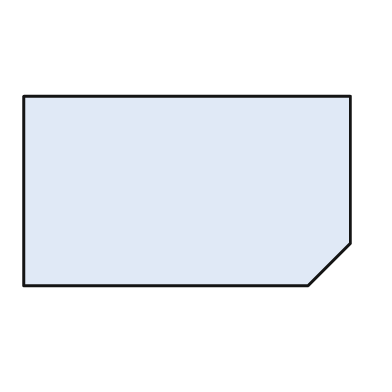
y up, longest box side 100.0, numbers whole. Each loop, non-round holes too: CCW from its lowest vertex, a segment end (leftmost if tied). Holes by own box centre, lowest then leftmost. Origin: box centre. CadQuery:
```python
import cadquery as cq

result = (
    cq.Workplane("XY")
    .moveTo(-50.0, -29.0)
    .lineTo(37.0, -29.0)
    .lineTo(50.0, -16.0)
    .lineTo(50.0, 29.0)
    .lineTo(-50.0, 29.0)
    .close()
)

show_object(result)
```